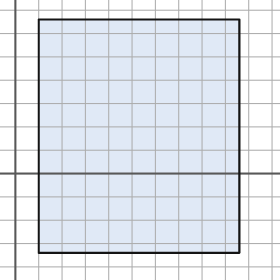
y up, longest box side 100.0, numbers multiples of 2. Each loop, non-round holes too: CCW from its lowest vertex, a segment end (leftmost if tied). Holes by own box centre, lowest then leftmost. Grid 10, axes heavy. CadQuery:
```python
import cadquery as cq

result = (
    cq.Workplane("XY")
    .moveTo(10.0, -34.0)
    .lineTo(96.0, -34.0)
    .lineTo(96.0, 66.0)
    .lineTo(10.0, 66.0)
    .close()
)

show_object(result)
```